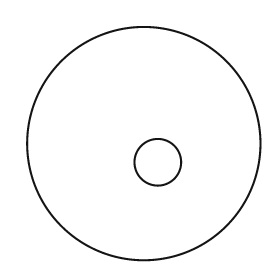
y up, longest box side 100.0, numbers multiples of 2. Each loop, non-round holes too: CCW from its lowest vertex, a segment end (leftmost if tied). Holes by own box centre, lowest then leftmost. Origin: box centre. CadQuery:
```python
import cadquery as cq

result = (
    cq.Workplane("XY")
    .moveTo(0.0, 0.0)
    .circle(50.0)
    .moveTo(6.0, -8.0)
    .circle(10.0)
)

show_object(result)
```